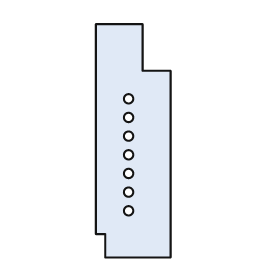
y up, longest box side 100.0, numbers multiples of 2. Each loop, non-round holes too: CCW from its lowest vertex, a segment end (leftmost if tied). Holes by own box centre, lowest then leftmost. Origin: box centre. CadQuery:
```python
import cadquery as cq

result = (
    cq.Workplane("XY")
    .moveTo(-12.0, -50.0)
    .lineTo(16.0, -50.0)
    .lineTo(16.0, 30.0)
    .lineTo(4.0, 30.0)
    .lineTo(4.0, 50.0)
    .lineTo(-16.0, 50.0)
    .lineTo(-16.0, -40.0)
    .lineTo(-12.0, -40.0)
    .close()
    .moveTo(-2.0, -30.0)
    .circle(2.0)
    .moveTo(-2.0, -22.0)
    .circle(2.0)
    .moveTo(-2.0, -14.0)
    .circle(2.0)
    .moveTo(-2.0, -6.0)
    .circle(2.0)
    .moveTo(-2.0, 2.0)
    .circle(2.0)
    .moveTo(-2.0, 10.0)
    .circle(2.0)
    .moveTo(-2.0, 18.0)
    .circle(2.0)
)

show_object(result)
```